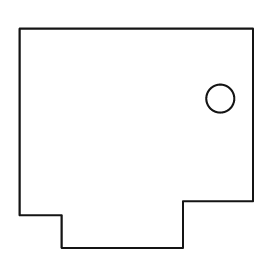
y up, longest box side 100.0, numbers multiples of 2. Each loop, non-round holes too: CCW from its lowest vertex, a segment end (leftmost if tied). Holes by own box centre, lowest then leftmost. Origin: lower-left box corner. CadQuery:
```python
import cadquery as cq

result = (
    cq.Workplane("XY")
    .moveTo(18.0, 0.0)
    .lineTo(70.0, 0.0)
    .lineTo(70.0, 20.0)
    .lineTo(100.0, 20.0)
    .lineTo(100.0, 94.0)
    .lineTo(0.0, 94.0)
    .lineTo(0.0, 14.0)
    .lineTo(18.0, 14.0)
    .close()
    .moveTo(86.0, 64.0)
    .circle(6.0)
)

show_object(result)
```